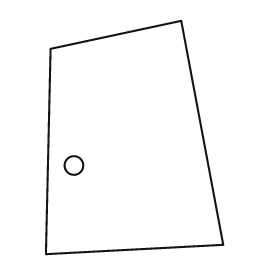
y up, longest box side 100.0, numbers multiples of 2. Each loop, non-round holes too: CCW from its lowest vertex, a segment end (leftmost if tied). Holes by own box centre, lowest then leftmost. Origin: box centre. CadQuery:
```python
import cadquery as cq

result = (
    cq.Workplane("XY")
    .moveTo(-38.0, -50.0)
    .lineTo(38.0, -46.0)
    .lineTo(20.0, 50.0)
    .lineTo(-36.0, 38.0)
    .close()
    .moveTo(-26.0, -12.0)
    .circle(4.0)
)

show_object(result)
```